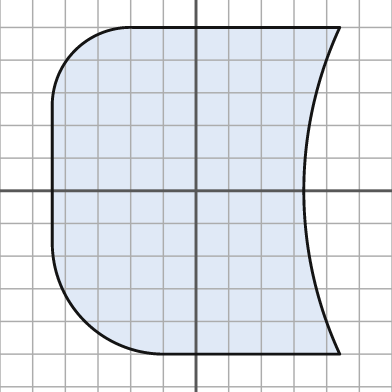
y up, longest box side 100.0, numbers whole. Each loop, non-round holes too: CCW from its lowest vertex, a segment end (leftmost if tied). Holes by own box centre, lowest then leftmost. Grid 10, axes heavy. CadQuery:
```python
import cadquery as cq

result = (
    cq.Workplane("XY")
    .moveTo(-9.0, -50.0)
    .lineTo(44.0, -50.0)
    .threePointArc((33.0, 0.0), (44.0, 50.0))
    .lineTo(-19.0, 50.0)
    .threePointArc((-37.0, 43.0), (-44.0, 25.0))
    .lineTo(-44.0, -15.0)
    .threePointArc((-34.0, -40.0), (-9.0, -50.0))
    .close()
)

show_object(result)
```